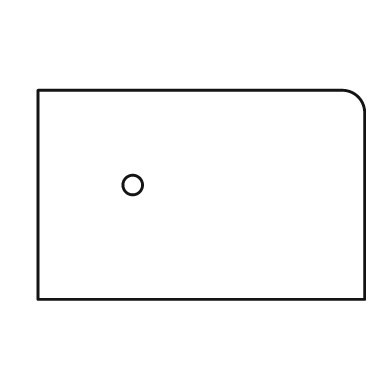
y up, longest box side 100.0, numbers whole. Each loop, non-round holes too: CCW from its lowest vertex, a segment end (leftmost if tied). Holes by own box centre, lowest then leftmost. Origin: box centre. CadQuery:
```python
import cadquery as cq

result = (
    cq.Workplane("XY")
    .moveTo(-50.0, -32.0)
    .lineTo(50.0, -32.0)
    .lineTo(50.0, 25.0)
    .threePointArc((48.0, 30.0), (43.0, 32.0))
    .lineTo(-50.0, 32.0)
    .close()
    .moveTo(-21.0, 3.0)
    .circle(3.0)
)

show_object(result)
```